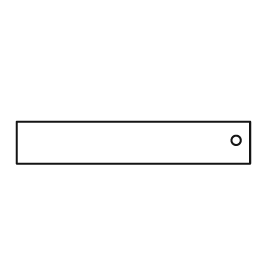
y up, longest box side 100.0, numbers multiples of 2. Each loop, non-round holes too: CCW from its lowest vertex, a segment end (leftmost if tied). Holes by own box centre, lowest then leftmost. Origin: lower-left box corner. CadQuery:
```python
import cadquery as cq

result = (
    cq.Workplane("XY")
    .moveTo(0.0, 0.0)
    .lineTo(100.0, 0.0)
    .lineTo(100.0, 18.0)
    .lineTo(0.0, 18.0)
    .close()
    .moveTo(94.0, 10.0)
    .circle(2.0)
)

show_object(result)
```